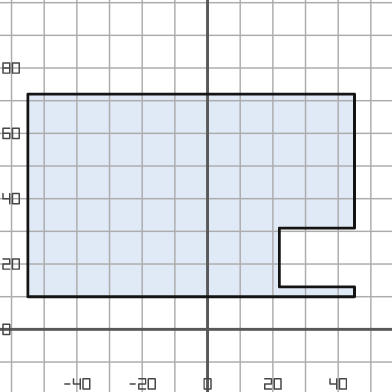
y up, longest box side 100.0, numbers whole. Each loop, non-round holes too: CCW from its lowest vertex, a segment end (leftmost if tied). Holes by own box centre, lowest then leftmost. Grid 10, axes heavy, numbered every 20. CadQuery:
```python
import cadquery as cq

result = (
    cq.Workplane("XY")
    .moveTo(-55.0, 10.0)
    .lineTo(45.0, 10.0)
    .lineTo(45.0, 13.0)
    .lineTo(22.0, 13.0)
    .lineTo(22.0, 31.0)
    .lineTo(45.0, 31.0)
    .lineTo(45.0, 72.0)
    .lineTo(-55.0, 72.0)
    .close()
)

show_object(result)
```